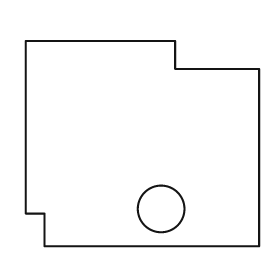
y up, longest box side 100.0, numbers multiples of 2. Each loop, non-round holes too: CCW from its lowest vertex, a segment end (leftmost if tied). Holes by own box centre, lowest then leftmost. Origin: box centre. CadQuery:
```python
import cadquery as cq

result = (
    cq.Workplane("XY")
    .moveTo(-42.0, -44.0)
    .lineTo(50.0, -44.0)
    .lineTo(50.0, 32.0)
    .lineTo(14.0, 32.0)
    .lineTo(14.0, 44.0)
    .lineTo(-50.0, 44.0)
    .lineTo(-50.0, -30.0)
    .lineTo(-42.0, -30.0)
    .close()
    .moveTo(8.0, -28.0)
    .circle(10.0)
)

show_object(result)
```